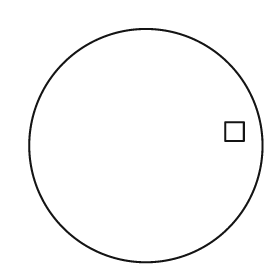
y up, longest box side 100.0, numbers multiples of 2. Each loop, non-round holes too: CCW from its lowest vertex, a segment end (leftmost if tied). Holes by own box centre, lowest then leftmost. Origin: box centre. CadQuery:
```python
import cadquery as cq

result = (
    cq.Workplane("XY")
    .moveTo(0.0, 0.0)
    .circle(50.0)
    .moveTo(34.0, 2.0)
    .lineTo(42.0, 2.0)
    .lineTo(42.0, 10.0)
    .lineTo(34.0, 10.0)
    .close()
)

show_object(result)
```